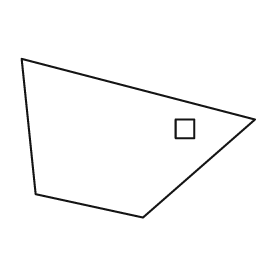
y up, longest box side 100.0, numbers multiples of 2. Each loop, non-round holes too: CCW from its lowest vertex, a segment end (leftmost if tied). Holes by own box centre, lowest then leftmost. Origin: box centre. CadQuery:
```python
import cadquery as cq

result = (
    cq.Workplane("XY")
    .moveTo(2.0, -34.0)
    .lineTo(50.0, 8.0)
    .lineTo(-50.0, 34.0)
    .lineTo(-44.0, -24.0)
    .close()
    .moveTo(16.0, 0.0)
    .lineTo(24.0, 0.0)
    .lineTo(24.0, 8.0)
    .lineTo(16.0, 8.0)
    .close()
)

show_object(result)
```